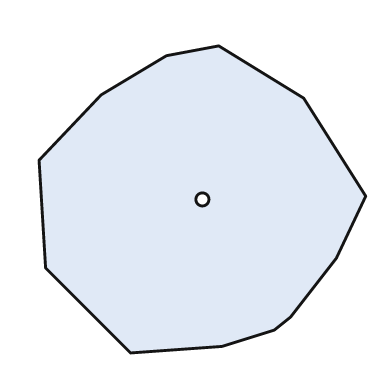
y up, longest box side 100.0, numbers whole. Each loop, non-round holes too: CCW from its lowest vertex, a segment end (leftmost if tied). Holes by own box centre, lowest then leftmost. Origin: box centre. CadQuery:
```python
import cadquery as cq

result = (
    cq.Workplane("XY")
    .moveTo(-22.0, -47.0)
    .lineTo(6.0, -45.0)
    .lineTo(22.0, -40.0)
    .lineTo(27.0, -36.0)
    .lineTo(41.0, -18.0)
    .lineTo(50.0, 1.0)
    .lineTo(31.0, 31.0)
    .lineTo(5.0, 47.0)
    .lineTo(-11.0, 44.0)
    .lineTo(-31.0, 32.0)
    .lineTo(-50.0, 12.0)
    .lineTo(-48.0, -21.0)
    .close()
    .moveTo(0.0, 0.0)
    .circle(2.0)
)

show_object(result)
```